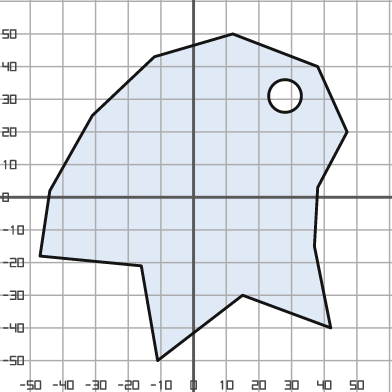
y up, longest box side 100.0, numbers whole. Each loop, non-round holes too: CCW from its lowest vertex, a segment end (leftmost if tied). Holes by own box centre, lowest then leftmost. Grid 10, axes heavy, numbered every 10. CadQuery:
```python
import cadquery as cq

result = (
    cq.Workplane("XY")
    .moveTo(-11.0, -50.0)
    .lineTo(15.0, -30.0)
    .lineTo(42.0, -40.0)
    .lineTo(37.0, -15.0)
    .lineTo(38.0, 3.0)
    .lineTo(47.0, 20.0)
    .lineTo(38.0, 40.0)
    .lineTo(12.0, 50.0)
    .lineTo(-12.0, 43.0)
    .lineTo(-31.0, 25.0)
    .lineTo(-44.0, 2.0)
    .lineTo(-47.0, -18.0)
    .lineTo(-16.0, -21.0)
    .close()
    .moveTo(28.0, 31.0)
    .circle(5.0)
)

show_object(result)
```